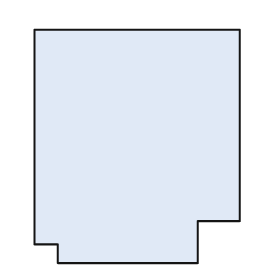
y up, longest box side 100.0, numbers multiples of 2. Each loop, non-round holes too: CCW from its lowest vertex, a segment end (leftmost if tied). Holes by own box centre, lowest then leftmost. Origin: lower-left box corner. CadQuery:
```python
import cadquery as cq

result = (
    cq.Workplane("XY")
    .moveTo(10.0, 0.0)
    .lineTo(70.0, 0.0)
    .lineTo(70.0, 18.0)
    .lineTo(88.0, 18.0)
    .lineTo(88.0, 100.0)
    .lineTo(0.0, 100.0)
    .lineTo(0.0, 8.0)
    .lineTo(10.0, 8.0)
    .close()
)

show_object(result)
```